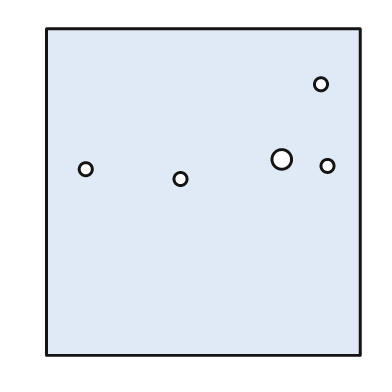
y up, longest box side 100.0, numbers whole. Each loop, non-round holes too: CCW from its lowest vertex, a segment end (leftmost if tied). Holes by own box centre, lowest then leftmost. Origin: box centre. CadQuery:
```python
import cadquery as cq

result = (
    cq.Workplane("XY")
    .moveTo(-48.0, -50.0)
    .lineTo(48.0, -50.0)
    .lineTo(48.0, 50.0)
    .lineTo(-48.0, 50.0)
    .close()
    .moveTo(-7.0, 4.0)
    .circle(2.0)
    .moveTo(-36.0, 7.0)
    .circle(2.0)
    .moveTo(38.0, 8.0)
    .circle(2.0)
    .moveTo(24.0, 10.0)
    .circle(3.0)
    .moveTo(36.0, 33.0)
    .circle(2.0)
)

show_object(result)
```